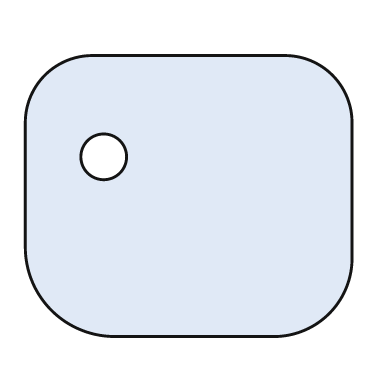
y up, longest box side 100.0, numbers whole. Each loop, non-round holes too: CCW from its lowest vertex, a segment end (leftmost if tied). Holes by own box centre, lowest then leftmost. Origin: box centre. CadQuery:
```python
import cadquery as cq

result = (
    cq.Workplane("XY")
    .moveTo(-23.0, -43.0)
    .lineTo(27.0, -43.0)
    .threePointArc((43.0, -36.0), (50.0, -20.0))
    .lineTo(50.0, 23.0)
    .threePointArc((44.0, 37.0), (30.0, 43.0))
    .lineTo(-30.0, 43.0)
    .threePointArc((-44.0, 37.0), (-50.0, 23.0))
    .lineTo(-50.0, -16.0)
    .threePointArc((-42.0, -35.0), (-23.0, -43.0))
    .close()
    .moveTo(-26.0, 12.0)
    .circle(7.0)
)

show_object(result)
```